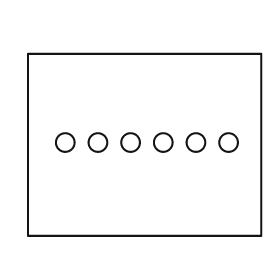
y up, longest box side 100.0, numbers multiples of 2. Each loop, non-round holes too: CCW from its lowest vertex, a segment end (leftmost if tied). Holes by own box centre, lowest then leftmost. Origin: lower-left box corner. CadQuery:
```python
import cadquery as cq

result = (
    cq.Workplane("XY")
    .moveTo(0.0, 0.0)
    .lineTo(100.0, 0.0)
    .lineTo(100.0, 78.0)
    .lineTo(0.0, 78.0)
    .close()
    .moveTo(16.0, 40.0)
    .circle(4.0)
    .moveTo(30.0, 40.0)
    .circle(4.0)
    .moveTo(44.0, 40.0)
    .circle(4.0)
    .moveTo(58.0, 40.0)
    .circle(4.0)
    .moveTo(72.0, 40.0)
    .circle(4.0)
    .moveTo(86.0, 40.0)
    .circle(4.0)
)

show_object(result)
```